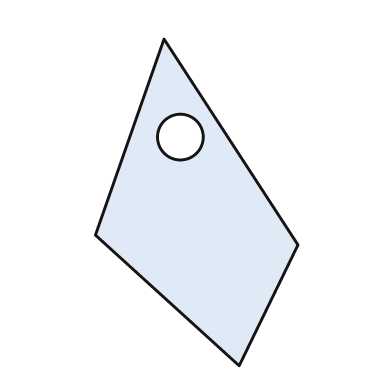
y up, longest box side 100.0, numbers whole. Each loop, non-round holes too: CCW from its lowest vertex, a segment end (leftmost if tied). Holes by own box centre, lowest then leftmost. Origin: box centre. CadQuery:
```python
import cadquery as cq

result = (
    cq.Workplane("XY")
    .moveTo(13.0, -50.0)
    .lineTo(31.0, -13.0)
    .lineTo(-10.0, 50.0)
    .lineTo(-31.0, -10.0)
    .close()
    .moveTo(-5.0, 20.0)
    .circle(7.0)
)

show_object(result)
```